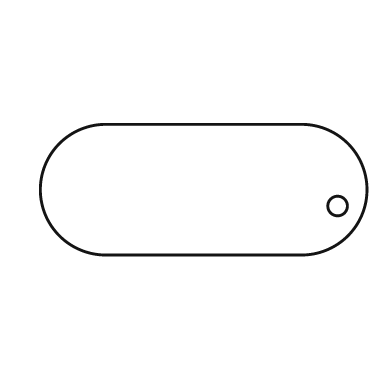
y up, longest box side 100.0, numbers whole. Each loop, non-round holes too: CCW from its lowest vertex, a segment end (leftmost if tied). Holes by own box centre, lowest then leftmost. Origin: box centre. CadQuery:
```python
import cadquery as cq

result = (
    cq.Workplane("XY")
    .moveTo(-30.0, -20.0)
    .lineTo(30.0, -20.0)
    .threePointArc((50.0, 0.0), (30.0, 20.0))
    .lineTo(-30.0, 20.0)
    .threePointArc((-50.0, 0.0), (-30.0, -20.0))
    .close()
    .moveTo(41.0, -5.0)
    .circle(3.0)
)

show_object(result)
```